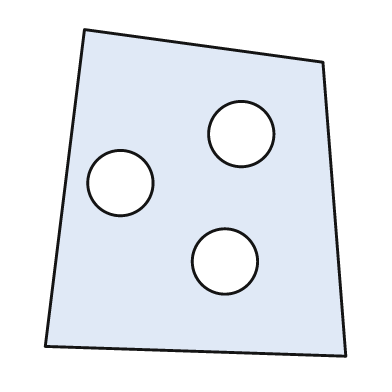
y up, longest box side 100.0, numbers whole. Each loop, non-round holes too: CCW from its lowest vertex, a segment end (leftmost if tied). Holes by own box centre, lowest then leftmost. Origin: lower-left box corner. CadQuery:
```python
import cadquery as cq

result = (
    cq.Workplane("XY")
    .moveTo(92.0, 0.0)
    .lineTo(85.0, 90.0)
    .lineTo(12.0, 100.0)
    .lineTo(0.0, 3.0)
    .close()
    .moveTo(55.0, 29.0)
    .circle(10.0)
    .moveTo(23.0, 53.0)
    .circle(10.0)
    .moveTo(60.0, 68.0)
    .circle(10.0)
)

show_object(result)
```